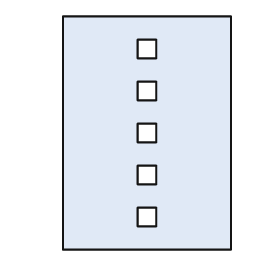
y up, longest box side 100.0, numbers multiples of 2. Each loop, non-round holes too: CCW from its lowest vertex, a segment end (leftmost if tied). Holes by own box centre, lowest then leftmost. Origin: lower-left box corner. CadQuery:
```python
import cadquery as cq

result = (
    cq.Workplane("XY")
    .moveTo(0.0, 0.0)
    .lineTo(72.0, 0.0)
    .lineTo(72.0, 100.0)
    .lineTo(0.0, 100.0)
    .close()
    .moveTo(32.0, 10.0)
    .lineTo(40.0, 10.0)
    .lineTo(40.0, 18.0)
    .lineTo(32.0, 18.0)
    .close()
    .moveTo(32.0, 28.0)
    .lineTo(40.0, 28.0)
    .lineTo(40.0, 36.0)
    .lineTo(32.0, 36.0)
    .close()
    .moveTo(32.0, 46.0)
    .lineTo(40.0, 46.0)
    .lineTo(40.0, 54.0)
    .lineTo(32.0, 54.0)
    .close()
    .moveTo(32.0, 64.0)
    .lineTo(40.0, 64.0)
    .lineTo(40.0, 72.0)
    .lineTo(32.0, 72.0)
    .close()
    .moveTo(32.0, 82.0)
    .lineTo(40.0, 82.0)
    .lineTo(40.0, 90.0)
    .lineTo(32.0, 90.0)
    .close()
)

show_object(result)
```